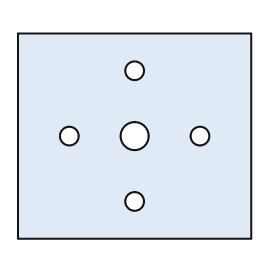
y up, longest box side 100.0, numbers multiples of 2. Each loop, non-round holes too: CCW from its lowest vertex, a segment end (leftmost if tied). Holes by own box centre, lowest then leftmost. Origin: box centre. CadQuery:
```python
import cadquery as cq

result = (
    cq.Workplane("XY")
    .moveTo(-50.0, -44.0)
    .lineTo(50.0, -44.0)
    .lineTo(50.0, 44.0)
    .lineTo(-50.0, 44.0)
    .close()
    .moveTo(0.0, -28.0)
    .circle(4.0)
    .moveTo(-28.0, 0.0)
    .circle(4.0)
    .moveTo(0.0, 0.0)
    .circle(6.0)
    .moveTo(28.0, 0.0)
    .circle(4.0)
    .moveTo(0.0, 28.0)
    .circle(4.0)
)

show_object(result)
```